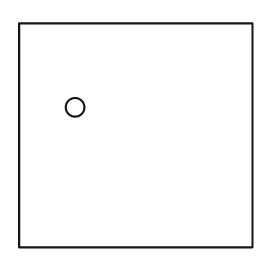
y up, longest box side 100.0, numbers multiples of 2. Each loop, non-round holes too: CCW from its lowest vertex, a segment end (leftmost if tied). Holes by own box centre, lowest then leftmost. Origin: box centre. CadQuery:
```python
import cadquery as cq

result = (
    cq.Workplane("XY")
    .moveTo(-50.0, -48.0)
    .lineTo(50.0, -48.0)
    .lineTo(50.0, 48.0)
    .lineTo(-50.0, 48.0)
    .close()
    .moveTo(-26.0, 12.0)
    .circle(4.0)
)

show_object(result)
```